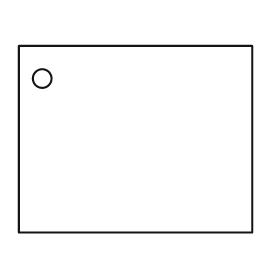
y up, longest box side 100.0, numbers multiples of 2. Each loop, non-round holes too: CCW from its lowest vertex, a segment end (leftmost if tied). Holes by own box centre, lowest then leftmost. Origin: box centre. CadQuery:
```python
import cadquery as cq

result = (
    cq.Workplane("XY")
    .moveTo(-50.0, -40.0)
    .lineTo(50.0, -40.0)
    .lineTo(50.0, 40.0)
    .lineTo(-50.0, 40.0)
    .close()
    .moveTo(-40.0, 26.0)
    .circle(4.0)
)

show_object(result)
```